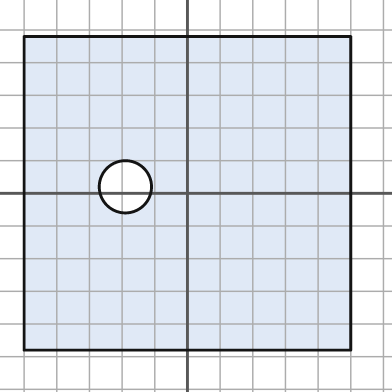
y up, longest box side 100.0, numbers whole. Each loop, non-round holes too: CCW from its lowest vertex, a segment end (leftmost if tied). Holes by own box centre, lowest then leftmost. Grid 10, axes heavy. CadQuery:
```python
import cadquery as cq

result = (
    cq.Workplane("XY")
    .moveTo(-50.0, -48.0)
    .lineTo(50.0, -48.0)
    .lineTo(50.0, 48.0)
    .lineTo(-50.0, 48.0)
    .close()
    .moveTo(-19.0, 2.0)
    .circle(8.0)
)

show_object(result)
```